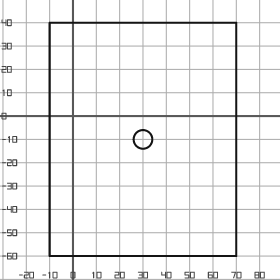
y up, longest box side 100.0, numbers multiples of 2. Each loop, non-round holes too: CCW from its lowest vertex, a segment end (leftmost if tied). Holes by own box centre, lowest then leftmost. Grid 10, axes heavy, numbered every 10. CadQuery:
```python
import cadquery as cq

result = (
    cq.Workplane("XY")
    .moveTo(-10.0, -60.0)
    .lineTo(70.0, -60.0)
    .lineTo(70.0, 40.0)
    .lineTo(-10.0, 40.0)
    .close()
    .moveTo(30.0, -10.0)
    .circle(4.0)
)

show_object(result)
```